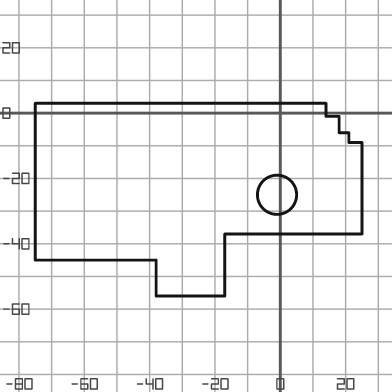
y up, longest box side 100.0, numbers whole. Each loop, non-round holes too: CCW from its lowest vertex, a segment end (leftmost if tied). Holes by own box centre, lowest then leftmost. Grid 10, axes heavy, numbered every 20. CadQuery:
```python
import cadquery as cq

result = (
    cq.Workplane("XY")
    .moveTo(-38.0, -56.0)
    .lineTo(-17.0, -56.0)
    .lineTo(-17.0, -37.0)
    .lineTo(25.0, -37.0)
    .lineTo(25.0, -9.0)
    .lineTo(21.0, -9.0)
    .lineTo(21.0, -6.0)
    .lineTo(18.0, -6.0)
    .lineTo(18.0, -1.0)
    .lineTo(14.0, -1.0)
    .lineTo(14.0, 3.0)
    .lineTo(-75.0, 3.0)
    .lineTo(-75.0, -45.0)
    .lineTo(-38.0, -45.0)
    .close()
    .moveTo(-1.0, -25.0)
    .circle(6.0)
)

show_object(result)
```